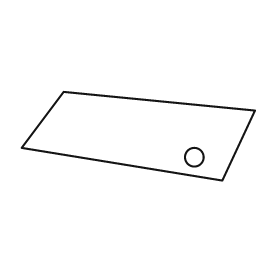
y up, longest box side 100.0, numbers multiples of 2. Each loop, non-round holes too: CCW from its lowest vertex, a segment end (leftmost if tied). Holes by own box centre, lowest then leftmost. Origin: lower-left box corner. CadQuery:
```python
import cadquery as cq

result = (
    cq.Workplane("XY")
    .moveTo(86.0, 0.0)
    .lineTo(100.0, 30.0)
    .lineTo(18.0, 38.0)
    .lineTo(0.0, 14.0)
    .close()
    .moveTo(74.0, 10.0)
    .circle(4.0)
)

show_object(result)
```